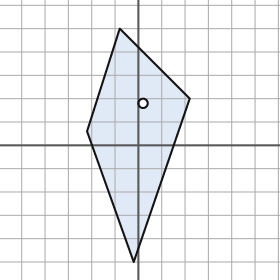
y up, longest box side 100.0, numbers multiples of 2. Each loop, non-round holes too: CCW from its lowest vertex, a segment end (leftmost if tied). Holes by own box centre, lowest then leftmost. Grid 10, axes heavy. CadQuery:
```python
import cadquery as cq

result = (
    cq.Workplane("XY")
    .moveTo(-2.0, -50.0)
    .lineTo(22.0, 20.0)
    .lineTo(-8.0, 50.0)
    .lineTo(-22.0, 6.0)
    .close()
    .moveTo(2.0, 18.0)
    .circle(2.0)
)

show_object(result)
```